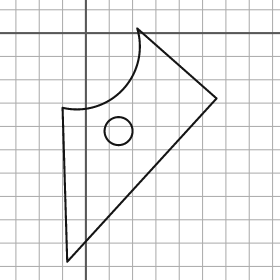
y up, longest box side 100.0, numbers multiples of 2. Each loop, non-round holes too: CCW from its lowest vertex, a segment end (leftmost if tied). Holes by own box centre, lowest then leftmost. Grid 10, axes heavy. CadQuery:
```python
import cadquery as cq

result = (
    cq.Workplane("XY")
    .moveTo(-8.0, -98.0)
    .lineTo(56.0, -28.0)
    .lineTo(22.0, 2.0)
    .threePointArc((16.0, -24.0), (-10.0, -32.0))
    .close()
    .moveTo(14.0, -42.0)
    .circle(6.0)
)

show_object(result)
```